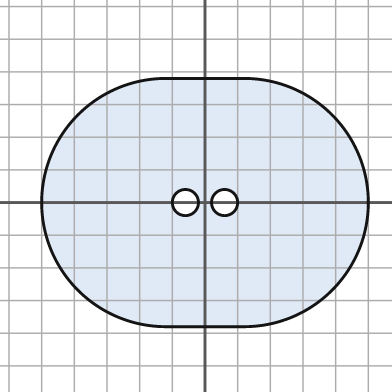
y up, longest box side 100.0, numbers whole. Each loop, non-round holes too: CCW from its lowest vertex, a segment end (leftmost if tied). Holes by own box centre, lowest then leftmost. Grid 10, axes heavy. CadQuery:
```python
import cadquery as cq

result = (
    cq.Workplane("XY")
    .moveTo(-12.0, -38.0)
    .lineTo(12.0, -38.0)
    .threePointArc((50.0, 0.0), (12.0, 38.0))
    .lineTo(-12.0, 38.0)
    .threePointArc((-50.0, 0.0), (-12.0, -38.0))
    .close()
    .moveTo(-6.0, 0.0)
    .circle(4.0)
    .moveTo(6.0, 0.0)
    .circle(4.0)
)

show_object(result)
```